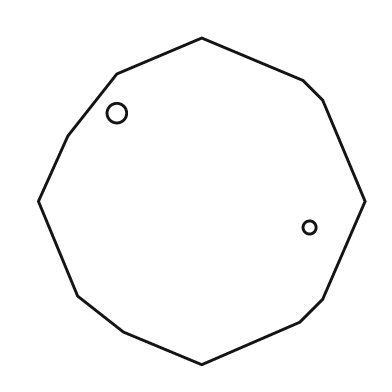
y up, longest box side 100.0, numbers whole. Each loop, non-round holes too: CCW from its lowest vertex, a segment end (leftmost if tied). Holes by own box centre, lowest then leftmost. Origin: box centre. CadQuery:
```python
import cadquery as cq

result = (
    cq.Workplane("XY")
    .moveTo(0.0, -50.0)
    .lineTo(30.0, -37.0)
    .lineTo(37.0, -30.0)
    .lineTo(50.0, 0.0)
    .lineTo(37.0, 31.0)
    .lineTo(31.0, 37.0)
    .lineTo(0.0, 50.0)
    .lineTo(-26.0, 39.0)
    .lineTo(-41.0, 20.0)
    .lineTo(-50.0, 0.0)
    .lineTo(-38.0, -29.0)
    .lineTo(-24.0, -40.0)
    .close()
    .moveTo(33.0, -8.0)
    .circle(2.0)
    .moveTo(-26.0, 27.0)
    .circle(3.0)
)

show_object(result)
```